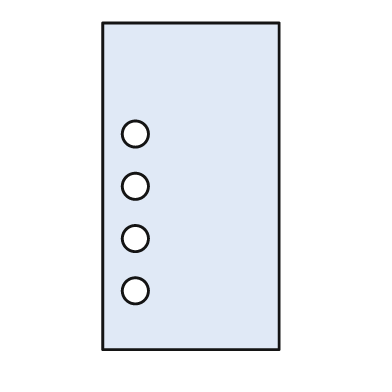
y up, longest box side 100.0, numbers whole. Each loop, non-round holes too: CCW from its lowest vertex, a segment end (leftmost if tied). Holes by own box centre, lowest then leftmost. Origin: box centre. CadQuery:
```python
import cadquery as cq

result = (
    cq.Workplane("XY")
    .moveTo(-27.0, -50.0)
    .lineTo(27.0, -50.0)
    .lineTo(27.0, 50.0)
    .lineTo(-27.0, 50.0)
    .close()
    .moveTo(-17.0, -32.0)
    .circle(4.0)
    .moveTo(-17.0, -16.0)
    .circle(4.0)
    .moveTo(-17.0, 0.0)
    .circle(4.0)
    .moveTo(-17.0, 16.0)
    .circle(4.0)
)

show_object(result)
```